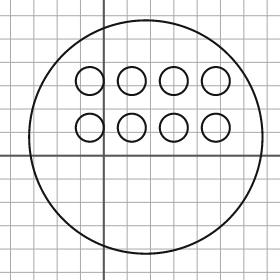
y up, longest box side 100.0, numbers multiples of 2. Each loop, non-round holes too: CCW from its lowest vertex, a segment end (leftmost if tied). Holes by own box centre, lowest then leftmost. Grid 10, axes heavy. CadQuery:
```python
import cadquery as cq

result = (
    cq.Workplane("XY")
    .moveTo(18.0, 8.0)
    .circle(50.0)
    .moveTo(-6.0, 12.0)
    .circle(6.0)
    .moveTo(12.0, 12.0)
    .circle(6.0)
    .moveTo(30.0, 12.0)
    .circle(6.0)
    .moveTo(48.0, 12.0)
    .circle(6.0)
    .moveTo(-6.0, 32.0)
    .circle(6.0)
    .moveTo(12.0, 32.0)
    .circle(6.0)
    .moveTo(30.0, 32.0)
    .circle(6.0)
    .moveTo(48.0, 32.0)
    .circle(6.0)
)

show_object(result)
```